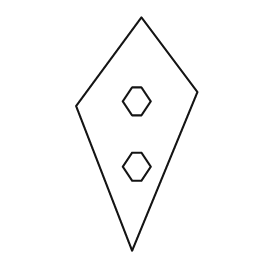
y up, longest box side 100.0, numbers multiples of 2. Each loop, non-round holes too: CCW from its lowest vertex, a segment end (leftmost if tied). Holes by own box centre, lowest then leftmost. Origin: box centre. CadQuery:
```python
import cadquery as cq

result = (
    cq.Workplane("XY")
    .moveTo(-2.0, -50.0)
    .lineTo(26.0, 18.0)
    .lineTo(2.0, 50.0)
    .lineTo(-26.0, 12.0)
    .close()
    .moveTo(-2.0, -20.0)
    .lineTo(2.0, -20.0)
    .lineTo(6.0, -14.0)
    .lineTo(2.0, -8.0)
    .lineTo(-2.0, -8.0)
    .lineTo(-6.0, -14.0)
    .close()
    .moveTo(-2.0, 8.0)
    .lineTo(2.0, 8.0)
    .lineTo(6.0, 14.0)
    .lineTo(2.0, 20.0)
    .lineTo(-2.0, 20.0)
    .lineTo(-6.0, 14.0)
    .close()
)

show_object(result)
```